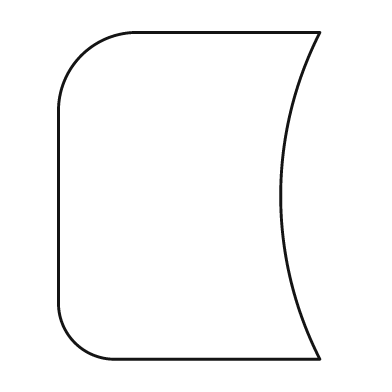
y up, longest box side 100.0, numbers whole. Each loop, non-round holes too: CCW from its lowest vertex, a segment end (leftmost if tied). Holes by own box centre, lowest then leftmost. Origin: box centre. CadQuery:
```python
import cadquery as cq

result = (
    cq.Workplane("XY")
    .moveTo(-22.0, -50.0)
    .lineTo(40.0, -50.0)
    .threePointArc((28.0, 0.0), (40.0, 50.0))
    .lineTo(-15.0, 50.0)
    .threePointArc((-33.0, 43.0), (-40.0, 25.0))
    .lineTo(-40.0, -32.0)
    .threePointArc((-35.0, -45.0), (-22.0, -50.0))
    .close()
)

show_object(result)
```